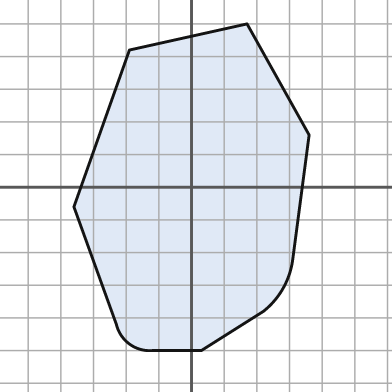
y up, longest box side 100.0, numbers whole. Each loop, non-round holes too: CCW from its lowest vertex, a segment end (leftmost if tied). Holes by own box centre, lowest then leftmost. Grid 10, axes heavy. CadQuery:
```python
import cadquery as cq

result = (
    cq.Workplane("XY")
    .moveTo(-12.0, -50.0)
    .lineTo(3.0, -50.0)
    .lineTo(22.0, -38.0)
    .threePointArc((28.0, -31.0), (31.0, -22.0))
    .lineTo(36.0, 16.0)
    .lineTo(17.0, 50.0)
    .lineTo(-19.0, 42.0)
    .lineTo(-36.0, -6.0)
    .lineTo(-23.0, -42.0)
    .threePointArc((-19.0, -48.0), (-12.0, -50.0))
    .close()
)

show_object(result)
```